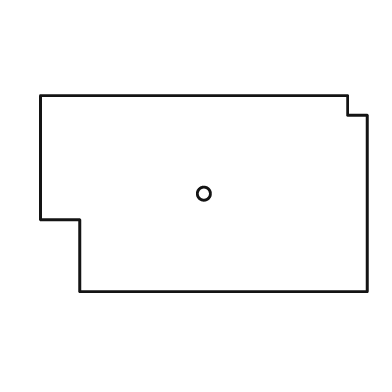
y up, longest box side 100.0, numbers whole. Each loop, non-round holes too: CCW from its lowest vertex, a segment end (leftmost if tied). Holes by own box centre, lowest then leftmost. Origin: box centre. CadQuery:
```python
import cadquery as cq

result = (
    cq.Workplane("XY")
    .moveTo(-38.0, -30.0)
    .lineTo(50.0, -30.0)
    .lineTo(50.0, 24.0)
    .lineTo(44.0, 24.0)
    .lineTo(44.0, 30.0)
    .lineTo(-50.0, 30.0)
    .lineTo(-50.0, -8.0)
    .lineTo(-38.0, -8.0)
    .close()
    .moveTo(0.0, 0.0)
    .circle(2.0)
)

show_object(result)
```